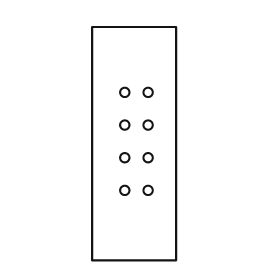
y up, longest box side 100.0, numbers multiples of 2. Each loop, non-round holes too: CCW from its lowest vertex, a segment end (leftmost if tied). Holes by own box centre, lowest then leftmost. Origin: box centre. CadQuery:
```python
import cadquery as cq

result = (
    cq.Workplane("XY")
    .moveTo(-18.0, -50.0)
    .lineTo(18.0, -50.0)
    .lineTo(18.0, 50.0)
    .lineTo(-18.0, 50.0)
    .close()
    .moveTo(-4.0, -20.0)
    .circle(2.0)
    .moveTo(6.0, -20.0)
    .circle(2.0)
    .moveTo(-4.0, -6.0)
    .circle(2.0)
    .moveTo(6.0, -6.0)
    .circle(2.0)
    .moveTo(-4.0, 8.0)
    .circle(2.0)
    .moveTo(6.0, 8.0)
    .circle(2.0)
    .moveTo(-4.0, 22.0)
    .circle(2.0)
    .moveTo(6.0, 22.0)
    .circle(2.0)
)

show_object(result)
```